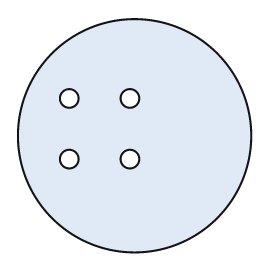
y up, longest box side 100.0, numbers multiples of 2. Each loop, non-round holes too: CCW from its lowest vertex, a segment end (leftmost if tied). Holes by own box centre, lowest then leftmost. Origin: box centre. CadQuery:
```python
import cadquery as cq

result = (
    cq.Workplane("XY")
    .moveTo(0.0, 0.0)
    .circle(50.0)
    .moveTo(-28.0, -10.0)
    .circle(4.0)
    .moveTo(-2.0, -10.0)
    .circle(4.0)
    .moveTo(-28.0, 16.0)
    .circle(4.0)
    .moveTo(-2.0, 16.0)
    .circle(4.0)
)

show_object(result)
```